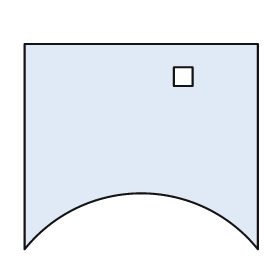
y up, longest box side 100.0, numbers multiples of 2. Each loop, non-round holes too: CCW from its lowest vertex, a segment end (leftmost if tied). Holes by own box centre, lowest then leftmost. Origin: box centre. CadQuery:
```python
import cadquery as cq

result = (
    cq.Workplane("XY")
    .moveTo(-50.0, -44.0)
    .threePointArc((0.0, -20.0), (50.0, -44.0))
    .lineTo(50.0, 44.0)
    .lineTo(-50.0, 44.0)
    .close()
    .moveTo(14.0, 26.0)
    .lineTo(22.0, 26.0)
    .lineTo(22.0, 34.0)
    .lineTo(14.0, 34.0)
    .close()
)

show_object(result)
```